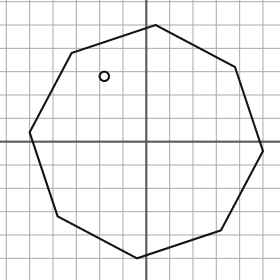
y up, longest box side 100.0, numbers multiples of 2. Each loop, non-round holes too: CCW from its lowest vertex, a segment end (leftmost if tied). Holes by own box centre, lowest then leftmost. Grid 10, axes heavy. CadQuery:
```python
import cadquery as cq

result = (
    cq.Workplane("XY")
    .moveTo(-4.0, -50.0)
    .lineTo(32.0, -38.0)
    .lineTo(50.0, -4.0)
    .lineTo(38.0, 32.0)
    .lineTo(4.0, 50.0)
    .lineTo(-32.0, 38.0)
    .lineTo(-50.0, 4.0)
    .lineTo(-38.0, -32.0)
    .close()
    .moveTo(-18.0, 28.0)
    .circle(2.0)
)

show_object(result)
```